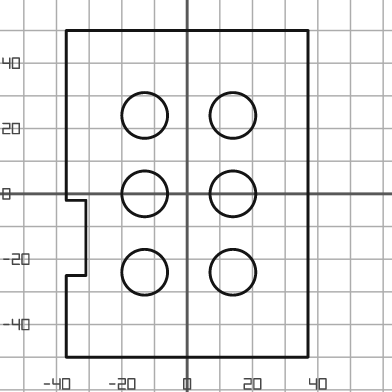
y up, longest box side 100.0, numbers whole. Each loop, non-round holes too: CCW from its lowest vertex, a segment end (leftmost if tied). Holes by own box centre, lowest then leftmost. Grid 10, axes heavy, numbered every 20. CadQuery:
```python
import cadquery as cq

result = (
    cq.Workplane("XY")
    .moveTo(-37.0, -50.0)
    .lineTo(37.0, -50.0)
    .lineTo(37.0, 50.0)
    .lineTo(-37.0, 50.0)
    .lineTo(-37.0, -2.0)
    .lineTo(-31.0, -2.0)
    .lineTo(-31.0, -25.0)
    .lineTo(-37.0, -25.0)
    .close()
    .moveTo(-13.0, -24.0)
    .circle(7.0)
    .moveTo(14.0, -24.0)
    .circle(7.0)
    .moveTo(-13.0, 0.0)
    .circle(7.0)
    .moveTo(14.0, 0.0)
    .circle(7.0)
    .moveTo(-13.0, 24.0)
    .circle(7.0)
    .moveTo(14.0, 24.0)
    .circle(7.0)
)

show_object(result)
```